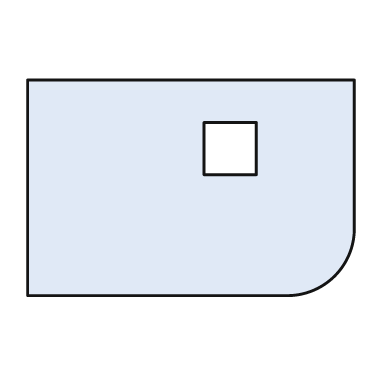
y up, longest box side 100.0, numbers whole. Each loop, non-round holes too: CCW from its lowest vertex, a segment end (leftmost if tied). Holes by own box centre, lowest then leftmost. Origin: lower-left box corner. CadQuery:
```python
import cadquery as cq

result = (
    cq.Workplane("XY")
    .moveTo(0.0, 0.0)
    .lineTo(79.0, 0.0)
    .threePointArc((94.0, 6.0), (100.0, 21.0))
    .lineTo(100.0, 66.0)
    .lineTo(0.0, 66.0)
    .close()
    .moveTo(54.0, 37.0)
    .lineTo(70.0, 37.0)
    .lineTo(70.0, 53.0)
    .lineTo(54.0, 53.0)
    .close()
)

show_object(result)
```